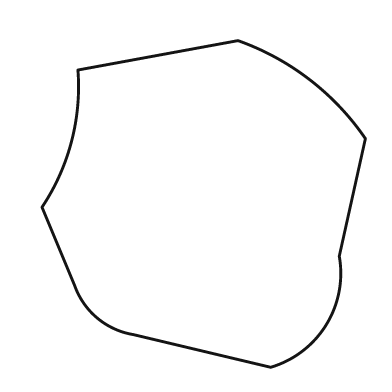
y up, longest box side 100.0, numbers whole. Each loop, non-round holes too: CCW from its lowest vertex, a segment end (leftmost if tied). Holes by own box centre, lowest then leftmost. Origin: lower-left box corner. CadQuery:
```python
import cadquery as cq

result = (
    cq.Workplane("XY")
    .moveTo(70.0, 0.0)
    .threePointArc((87.0, 13.0), (91.0, 34.0))
    .lineTo(99.0, 70.0)
    .threePointArc((82.0, 88.0), (60.0, 100.0))
    .lineTo(11.0, 91.0)
    .threePointArc((9.0, 69.0), (0.0, 49.0))
    .lineTo(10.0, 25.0)
    .threePointArc((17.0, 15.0), (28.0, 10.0))
    .close()
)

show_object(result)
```